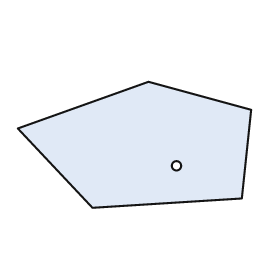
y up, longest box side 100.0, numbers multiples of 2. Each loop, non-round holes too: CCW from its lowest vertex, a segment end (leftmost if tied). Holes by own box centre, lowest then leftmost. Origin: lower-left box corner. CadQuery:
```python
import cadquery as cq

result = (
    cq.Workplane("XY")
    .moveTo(32.0, 0.0)
    .lineTo(96.0, 4.0)
    .lineTo(100.0, 42.0)
    .lineTo(56.0, 54.0)
    .lineTo(0.0, 34.0)
    .close()
    .moveTo(68.0, 18.0)
    .circle(2.0)
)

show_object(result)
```